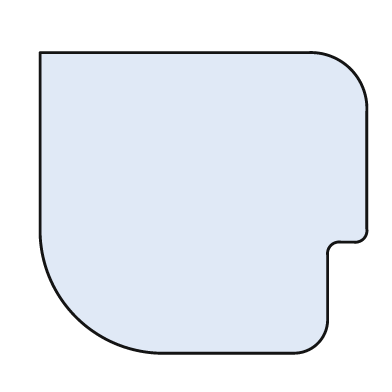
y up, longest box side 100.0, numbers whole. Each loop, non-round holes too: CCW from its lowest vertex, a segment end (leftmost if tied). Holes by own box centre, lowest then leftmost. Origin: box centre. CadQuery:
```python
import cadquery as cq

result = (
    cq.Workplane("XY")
    .moveTo(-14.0, -46.0)
    .lineTo(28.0, -46.0)
    .threePointArc((35.0, -43.0), (38.0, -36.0))
    .lineTo(38.0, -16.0)
    .threePointArc((39.0, -13.0), (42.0, -12.0))
    .lineTo(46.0, -12.0)
    .threePointArc((49.0, -11.0), (50.0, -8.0))
    .lineTo(50.0, 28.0)
    .threePointArc((45.0, 41.0), (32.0, 46.0))
    .lineTo(-50.0, 46.0)
    .lineTo(-50.0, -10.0)
    .threePointArc((-39.0, -35.0), (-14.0, -46.0))
    .close()
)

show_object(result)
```